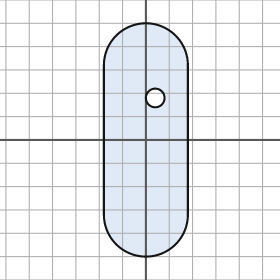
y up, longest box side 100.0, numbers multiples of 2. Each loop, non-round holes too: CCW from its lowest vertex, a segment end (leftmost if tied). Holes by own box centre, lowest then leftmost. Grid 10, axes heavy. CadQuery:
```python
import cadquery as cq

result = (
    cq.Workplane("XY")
    .moveTo(-18.0, -32.0)
    .threePointArc((0.0, -50.0), (18.0, -32.0))
    .lineTo(18.0, 32.0)
    .threePointArc((0.0, 50.0), (-18.0, 32.0))
    .close()
    .moveTo(4.0, 18.0)
    .circle(4.0)
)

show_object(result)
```